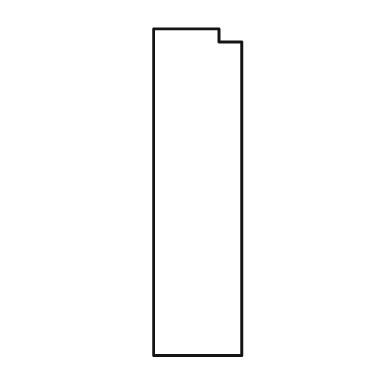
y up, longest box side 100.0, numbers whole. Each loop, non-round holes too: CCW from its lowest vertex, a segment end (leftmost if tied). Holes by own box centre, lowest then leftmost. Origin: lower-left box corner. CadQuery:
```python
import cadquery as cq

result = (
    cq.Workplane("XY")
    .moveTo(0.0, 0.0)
    .lineTo(27.0, 0.0)
    .lineTo(27.0, 96.0)
    .lineTo(20.0, 96.0)
    .lineTo(20.0, 100.0)
    .lineTo(0.0, 100.0)
    .close()
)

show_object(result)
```